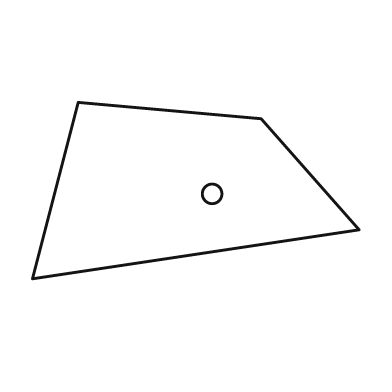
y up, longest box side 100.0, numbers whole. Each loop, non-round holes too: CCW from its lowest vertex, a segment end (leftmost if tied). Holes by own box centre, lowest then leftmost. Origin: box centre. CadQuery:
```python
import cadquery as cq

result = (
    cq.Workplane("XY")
    .moveTo(-50.0, -27.0)
    .lineTo(50.0, -12.0)
    .lineTo(20.0, 22.0)
    .lineTo(-36.0, 27.0)
    .close()
    .moveTo(5.0, -1.0)
    .circle(3.0)
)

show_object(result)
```